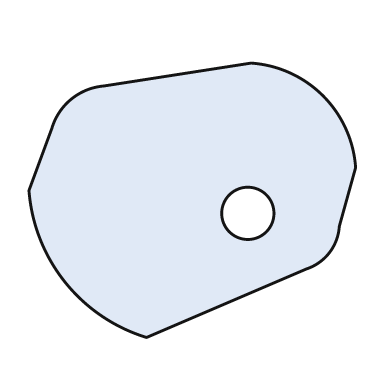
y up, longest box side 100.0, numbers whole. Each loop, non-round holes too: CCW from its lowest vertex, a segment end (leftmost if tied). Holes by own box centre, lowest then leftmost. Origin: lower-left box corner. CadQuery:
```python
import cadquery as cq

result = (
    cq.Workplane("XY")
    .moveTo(36.0, 0.0)
    .lineTo(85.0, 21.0)
    .threePointArc((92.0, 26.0), (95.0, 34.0))
    .lineTo(100.0, 52.0)
    .threePointArc((90.0, 74.0), (68.0, 84.0))
    .lineTo(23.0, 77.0)
    .threePointArc((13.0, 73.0), (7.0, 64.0))
    .lineTo(0.0, 45.0)
    .threePointArc((11.0, 17.0), (36.0, 0.0))
    .close()
    .moveTo(67.0, 38.0)
    .circle(8.0)
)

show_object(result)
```